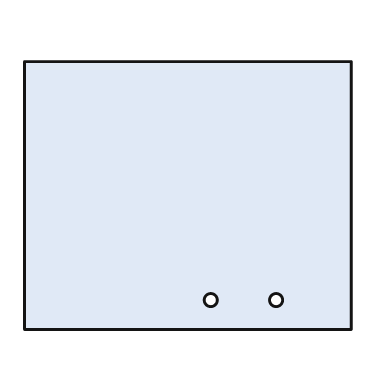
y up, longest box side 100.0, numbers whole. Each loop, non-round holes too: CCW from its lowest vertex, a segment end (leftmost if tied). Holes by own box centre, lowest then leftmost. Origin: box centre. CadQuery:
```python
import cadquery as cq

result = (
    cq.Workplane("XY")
    .moveTo(-50.0, -41.0)
    .lineTo(50.0, -41.0)
    .lineTo(50.0, 41.0)
    .lineTo(-50.0, 41.0)
    .close()
    .moveTo(7.0, -32.0)
    .circle(2.0)
    .moveTo(27.0, -32.0)
    .circle(2.0)
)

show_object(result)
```